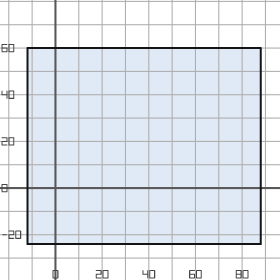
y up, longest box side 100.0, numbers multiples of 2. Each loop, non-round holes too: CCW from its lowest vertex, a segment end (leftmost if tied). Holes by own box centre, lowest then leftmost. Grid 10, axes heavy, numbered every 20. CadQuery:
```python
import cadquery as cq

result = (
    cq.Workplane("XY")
    .moveTo(-12.0, -24.0)
    .lineTo(88.0, -24.0)
    .lineTo(88.0, 60.0)
    .lineTo(-12.0, 60.0)
    .close()
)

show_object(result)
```